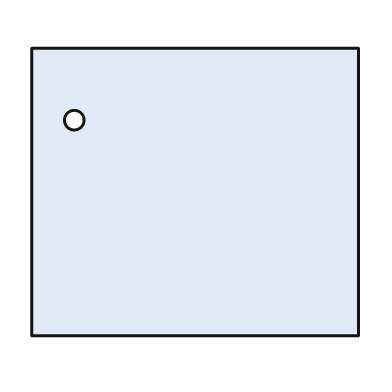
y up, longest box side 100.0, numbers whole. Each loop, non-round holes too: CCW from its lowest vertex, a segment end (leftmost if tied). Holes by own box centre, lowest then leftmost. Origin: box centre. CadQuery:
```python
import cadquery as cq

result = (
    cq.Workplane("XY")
    .moveTo(-50.0, -44.0)
    .lineTo(50.0, -44.0)
    .lineTo(50.0, 44.0)
    .lineTo(-50.0, 44.0)
    .close()
    .moveTo(-37.0, 22.0)
    .circle(3.0)
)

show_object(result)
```